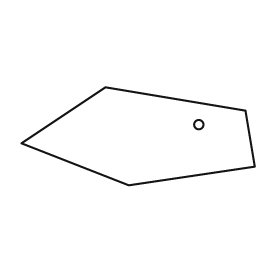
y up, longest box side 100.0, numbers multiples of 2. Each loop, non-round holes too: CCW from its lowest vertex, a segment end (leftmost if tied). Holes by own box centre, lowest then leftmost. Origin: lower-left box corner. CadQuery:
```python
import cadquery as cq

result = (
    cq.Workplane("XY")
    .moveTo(46.0, 0.0)
    .lineTo(100.0, 8.0)
    .lineTo(96.0, 32.0)
    .lineTo(36.0, 42.0)
    .lineTo(0.0, 18.0)
    .close()
    .moveTo(76.0, 26.0)
    .circle(2.0)
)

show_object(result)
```